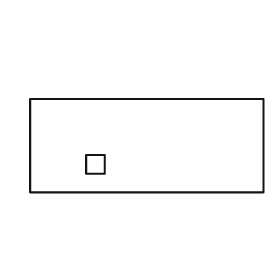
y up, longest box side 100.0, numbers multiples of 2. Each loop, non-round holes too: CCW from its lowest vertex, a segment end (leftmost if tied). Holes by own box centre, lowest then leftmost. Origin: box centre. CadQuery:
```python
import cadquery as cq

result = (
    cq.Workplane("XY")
    .moveTo(-50.0, -20.0)
    .lineTo(50.0, -20.0)
    .lineTo(50.0, 20.0)
    .lineTo(-50.0, 20.0)
    .close()
    .moveTo(-26.0, -12.0)
    .lineTo(-18.0, -12.0)
    .lineTo(-18.0, -4.0)
    .lineTo(-26.0, -4.0)
    .close()
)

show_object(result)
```